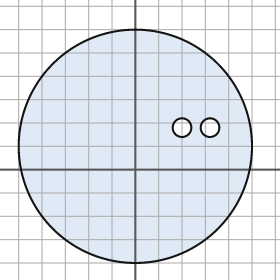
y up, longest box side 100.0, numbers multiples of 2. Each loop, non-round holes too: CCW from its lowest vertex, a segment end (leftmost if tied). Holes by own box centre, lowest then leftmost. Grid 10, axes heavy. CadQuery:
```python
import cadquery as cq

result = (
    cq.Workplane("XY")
    .moveTo(0.0, 10.0)
    .circle(50.0)
    .moveTo(20.0, 18.0)
    .circle(4.0)
    .moveTo(32.0, 18.0)
    .circle(4.0)
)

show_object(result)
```